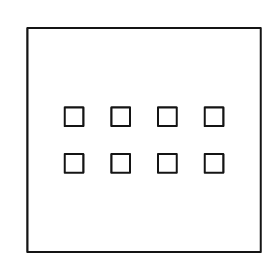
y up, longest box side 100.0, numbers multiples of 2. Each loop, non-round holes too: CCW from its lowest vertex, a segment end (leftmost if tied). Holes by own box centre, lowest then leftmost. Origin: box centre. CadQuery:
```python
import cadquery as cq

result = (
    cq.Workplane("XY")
    .moveTo(-50.0, -48.0)
    .lineTo(50.0, -48.0)
    .lineTo(50.0, 48.0)
    .lineTo(-50.0, 48.0)
    .close()
    .moveTo(-34.0, -14.0)
    .lineTo(-26.0, -14.0)
    .lineTo(-26.0, -6.0)
    .lineTo(-34.0, -6.0)
    .close()
    .moveTo(-14.0, -14.0)
    .lineTo(-6.0, -14.0)
    .lineTo(-6.0, -6.0)
    .lineTo(-14.0, -6.0)
    .close()
    .moveTo(6.0, -14.0)
    .lineTo(14.0, -14.0)
    .lineTo(14.0, -6.0)
    .lineTo(6.0, -6.0)
    .close()
    .moveTo(26.0, -14.0)
    .lineTo(34.0, -14.0)
    .lineTo(34.0, -6.0)
    .lineTo(26.0, -6.0)
    .close()
    .moveTo(-34.0, 6.0)
    .lineTo(-26.0, 6.0)
    .lineTo(-26.0, 14.0)
    .lineTo(-34.0, 14.0)
    .close()
    .moveTo(-14.0, 6.0)
    .lineTo(-6.0, 6.0)
    .lineTo(-6.0, 14.0)
    .lineTo(-14.0, 14.0)
    .close()
    .moveTo(6.0, 6.0)
    .lineTo(14.0, 6.0)
    .lineTo(14.0, 14.0)
    .lineTo(6.0, 14.0)
    .close()
    .moveTo(26.0, 6.0)
    .lineTo(34.0, 6.0)
    .lineTo(34.0, 14.0)
    .lineTo(26.0, 14.0)
    .close()
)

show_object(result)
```